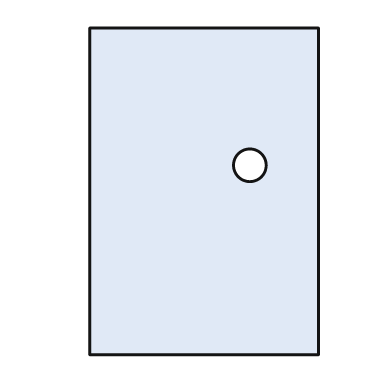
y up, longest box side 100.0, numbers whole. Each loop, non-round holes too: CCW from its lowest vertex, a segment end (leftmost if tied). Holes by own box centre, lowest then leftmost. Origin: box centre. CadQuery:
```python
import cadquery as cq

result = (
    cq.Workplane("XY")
    .moveTo(-35.0, -50.0)
    .lineTo(35.0, -50.0)
    .lineTo(35.0, 50.0)
    .lineTo(-35.0, 50.0)
    .close()
    .moveTo(14.0, 8.0)
    .circle(5.0)
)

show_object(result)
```